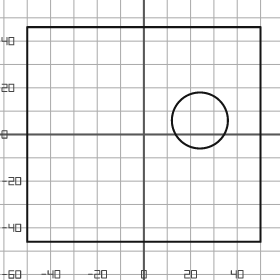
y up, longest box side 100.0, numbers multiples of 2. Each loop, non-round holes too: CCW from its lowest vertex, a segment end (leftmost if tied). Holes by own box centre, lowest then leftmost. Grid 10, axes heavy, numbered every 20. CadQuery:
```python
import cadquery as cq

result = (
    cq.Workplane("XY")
    .moveTo(-50.0, -46.0)
    .lineTo(50.0, -46.0)
    .lineTo(50.0, 46.0)
    .lineTo(-50.0, 46.0)
    .close()
    .moveTo(24.0, 6.0)
    .circle(12.0)
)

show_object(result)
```